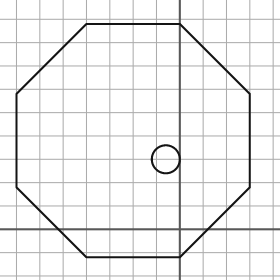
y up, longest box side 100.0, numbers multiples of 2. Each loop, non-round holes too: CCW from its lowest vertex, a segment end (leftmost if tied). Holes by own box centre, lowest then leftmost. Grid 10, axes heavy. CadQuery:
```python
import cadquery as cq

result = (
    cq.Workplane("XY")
    .moveTo(-40.0, -12.0)
    .lineTo(0.0, -12.0)
    .lineTo(30.0, 18.0)
    .lineTo(30.0, 58.0)
    .lineTo(0.0, 88.0)
    .lineTo(-40.0, 88.0)
    .lineTo(-70.0, 58.0)
    .lineTo(-70.0, 18.0)
    .close()
    .moveTo(-6.0, 30.0)
    .circle(6.0)
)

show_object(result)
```